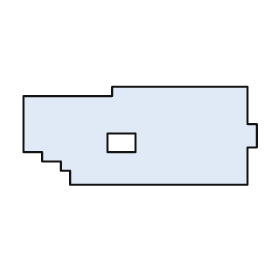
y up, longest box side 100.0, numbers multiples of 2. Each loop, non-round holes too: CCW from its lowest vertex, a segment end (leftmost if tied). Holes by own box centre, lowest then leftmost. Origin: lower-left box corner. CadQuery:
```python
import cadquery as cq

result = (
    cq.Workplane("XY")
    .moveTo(20.0, 0.0)
    .lineTo(96.0, 0.0)
    .lineTo(96.0, 16.0)
    .lineTo(100.0, 16.0)
    .lineTo(100.0, 26.0)
    .lineTo(96.0, 26.0)
    .lineTo(96.0, 42.0)
    .lineTo(38.0, 42.0)
    .lineTo(38.0, 38.0)
    .lineTo(0.0, 38.0)
    .lineTo(0.0, 14.0)
    .lineTo(8.0, 14.0)
    .lineTo(8.0, 10.0)
    .lineTo(16.0, 10.0)
    .lineTo(16.0, 6.0)
    .lineTo(20.0, 6.0)
    .close()
    .moveTo(36.0, 14.0)
    .lineTo(48.0, 14.0)
    .lineTo(48.0, 22.0)
    .lineTo(36.0, 22.0)
    .close()
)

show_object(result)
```